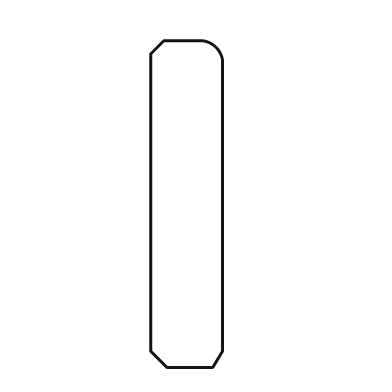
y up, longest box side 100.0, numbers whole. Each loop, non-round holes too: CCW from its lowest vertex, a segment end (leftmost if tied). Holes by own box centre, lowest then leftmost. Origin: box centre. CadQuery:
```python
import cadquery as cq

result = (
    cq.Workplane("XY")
    .moveTo(-6.0, -50.0)
    .lineTo(8.0, -50.0)
    .lineTo(11.0, -45.0)
    .lineTo(11.0, 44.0)
    .threePointArc((9.0, 48.0), (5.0, 50.0))
    .lineTo(-7.0, 50.0)
    .lineTo(-11.0, 46.0)
    .lineTo(-11.0, -45.0)
    .close()
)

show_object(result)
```